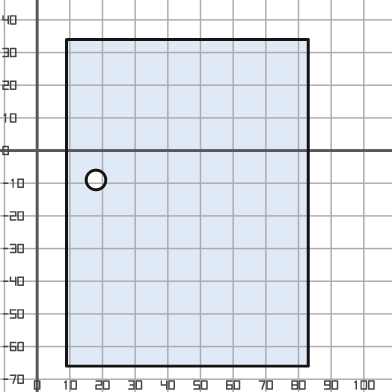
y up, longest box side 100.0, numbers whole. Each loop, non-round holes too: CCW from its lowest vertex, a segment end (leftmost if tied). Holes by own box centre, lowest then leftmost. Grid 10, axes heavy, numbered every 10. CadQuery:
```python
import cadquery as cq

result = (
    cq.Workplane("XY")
    .moveTo(9.0, -66.0)
    .lineTo(83.0, -66.0)
    .lineTo(83.0, 34.0)
    .lineTo(9.0, 34.0)
    .close()
    .moveTo(18.0, -9.0)
    .circle(3.0)
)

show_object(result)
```